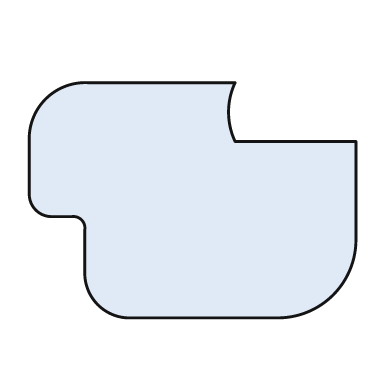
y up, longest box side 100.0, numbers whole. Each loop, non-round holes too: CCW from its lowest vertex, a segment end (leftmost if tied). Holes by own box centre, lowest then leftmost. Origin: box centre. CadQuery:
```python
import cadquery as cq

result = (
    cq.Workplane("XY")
    .moveTo(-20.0, -36.0)
    .lineTo(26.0, -36.0)
    .threePointArc((43.0, -29.0), (50.0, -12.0))
    .lineTo(50.0, 18.0)
    .lineTo(13.0, 18.0)
    .threePointArc((11.0, 27.0), (13.0, 36.0))
    .lineTo(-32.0, 36.0)
    .threePointArc((-45.0, 31.0), (-50.0, 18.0))
    .lineTo(-50.0, 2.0)
    .threePointArc((-48.0, -3.0), (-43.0, -5.0))
    .lineTo(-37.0, -5.0)
    .threePointArc((-34.0, -6.0), (-33.0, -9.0))
    .lineTo(-33.0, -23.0)
    .threePointArc((-29.0, -32.0), (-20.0, -36.0))
    .close()
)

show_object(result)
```